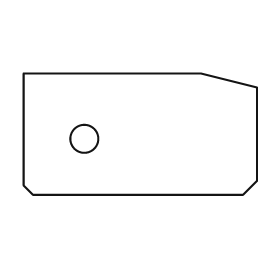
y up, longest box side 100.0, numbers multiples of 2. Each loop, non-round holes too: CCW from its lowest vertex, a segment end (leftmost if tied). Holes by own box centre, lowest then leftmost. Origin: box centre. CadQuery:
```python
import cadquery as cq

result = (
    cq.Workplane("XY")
    .moveTo(-46.0, -26.0)
    .lineTo(44.0, -26.0)
    .lineTo(50.0, -20.0)
    .lineTo(50.0, 20.0)
    .lineTo(26.0, 26.0)
    .lineTo(-50.0, 26.0)
    .lineTo(-50.0, -22.0)
    .close()
    .moveTo(-24.0, -2.0)
    .circle(6.0)
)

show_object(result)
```